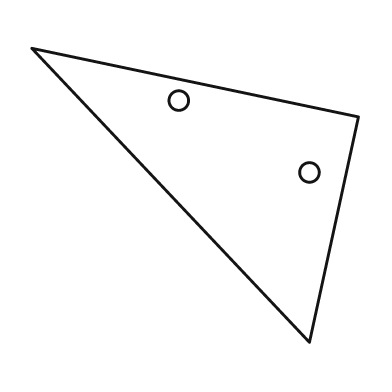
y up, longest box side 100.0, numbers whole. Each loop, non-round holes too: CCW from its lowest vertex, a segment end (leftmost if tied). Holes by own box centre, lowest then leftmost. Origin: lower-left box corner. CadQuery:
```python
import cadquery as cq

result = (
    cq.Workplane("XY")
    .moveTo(85.0, 0.0)
    .lineTo(100.0, 69.0)
    .lineTo(0.0, 90.0)
    .close()
    .moveTo(85.0, 52.0)
    .circle(3.0)
    .moveTo(45.0, 74.0)
    .circle(3.0)
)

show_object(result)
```